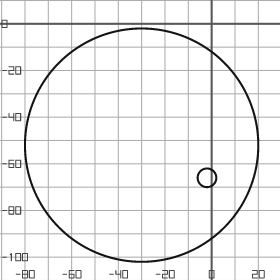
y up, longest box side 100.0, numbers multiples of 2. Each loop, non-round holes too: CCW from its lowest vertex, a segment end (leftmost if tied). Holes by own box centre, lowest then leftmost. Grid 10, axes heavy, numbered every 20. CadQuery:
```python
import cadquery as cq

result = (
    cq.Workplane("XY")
    .moveTo(-30.0, -52.0)
    .circle(50.0)
    .moveTo(-2.0, -66.0)
    .circle(4.0)
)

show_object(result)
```